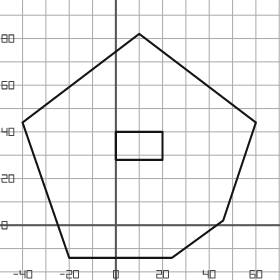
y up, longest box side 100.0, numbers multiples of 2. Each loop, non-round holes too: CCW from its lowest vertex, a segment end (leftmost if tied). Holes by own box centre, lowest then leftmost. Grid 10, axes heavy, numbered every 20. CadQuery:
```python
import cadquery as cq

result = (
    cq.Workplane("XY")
    .moveTo(-20.0, -14.0)
    .lineTo(24.0, -14.0)
    .lineTo(46.0, 2.0)
    .lineTo(60.0, 44.0)
    .lineTo(10.0, 82.0)
    .lineTo(-40.0, 44.0)
    .close()
    .moveTo(0.0, 28.0)
    .lineTo(20.0, 28.0)
    .lineTo(20.0, 40.0)
    .lineTo(0.0, 40.0)
    .close()
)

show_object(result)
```